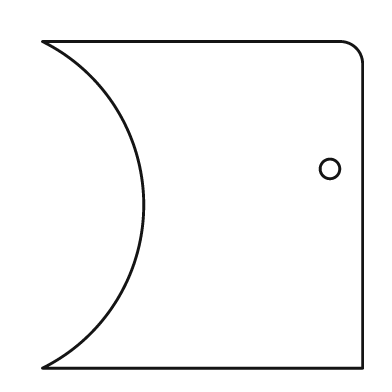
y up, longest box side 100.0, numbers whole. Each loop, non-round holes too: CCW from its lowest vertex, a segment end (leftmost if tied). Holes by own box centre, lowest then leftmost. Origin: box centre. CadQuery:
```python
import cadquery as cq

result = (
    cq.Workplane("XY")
    .moveTo(-49.0, -50.0)
    .lineTo(49.0, -50.0)
    .lineTo(49.0, 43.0)
    .threePointArc((47.0, 48.0), (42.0, 50.0))
    .lineTo(-49.0, 50.0)
    .threePointArc((-18.0, 0.0), (-49.0, -50.0))
    .close()
    .moveTo(39.0, 11.0)
    .circle(3.0)
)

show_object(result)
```